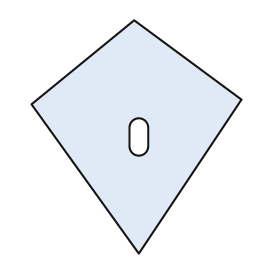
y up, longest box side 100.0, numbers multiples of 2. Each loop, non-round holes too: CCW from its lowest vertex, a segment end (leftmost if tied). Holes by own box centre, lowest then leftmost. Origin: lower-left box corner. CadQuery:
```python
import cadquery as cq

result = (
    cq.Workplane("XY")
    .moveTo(46.0, 0.0)
    .lineTo(90.0, 66.0)
    .lineTo(44.0, 100.0)
    .lineTo(0.0, 64.0)
    .close()
    .moveTo(42.0, 46.0)
    .threePointArc((46.0, 42.0), (50.0, 46.0))
    .lineTo(50.0, 54.0)
    .threePointArc((46.0, 58.0), (42.0, 54.0))
    .close()
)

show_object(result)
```